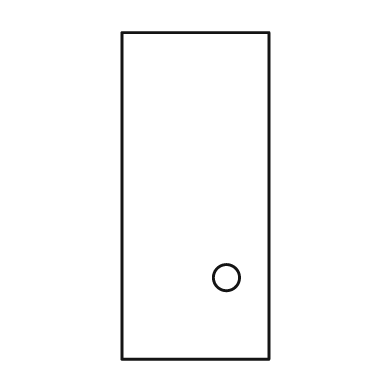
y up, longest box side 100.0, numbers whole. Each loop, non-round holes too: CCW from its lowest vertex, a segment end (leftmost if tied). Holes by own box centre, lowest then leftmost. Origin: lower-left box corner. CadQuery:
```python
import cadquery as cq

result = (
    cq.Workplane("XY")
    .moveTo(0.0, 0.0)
    .lineTo(45.0, 0.0)
    .lineTo(45.0, 100.0)
    .lineTo(0.0, 100.0)
    .close()
    .moveTo(32.0, 25.0)
    .circle(4.0)
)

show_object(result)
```